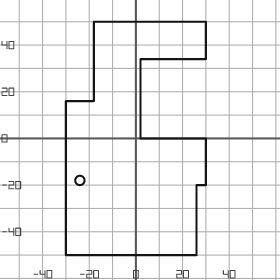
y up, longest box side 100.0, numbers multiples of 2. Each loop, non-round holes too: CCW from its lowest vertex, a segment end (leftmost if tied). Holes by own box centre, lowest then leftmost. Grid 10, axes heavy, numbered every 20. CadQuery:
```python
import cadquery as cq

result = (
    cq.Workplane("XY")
    .moveTo(-30.0, -50.0)
    .lineTo(26.0, -50.0)
    .lineTo(26.0, -20.0)
    .lineTo(30.0, -20.0)
    .lineTo(30.0, 0.0)
    .lineTo(2.0, 0.0)
    .lineTo(2.0, 34.0)
    .lineTo(30.0, 34.0)
    .lineTo(30.0, 50.0)
    .lineTo(-18.0, 50.0)
    .lineTo(-18.0, 16.0)
    .lineTo(-30.0, 16.0)
    .close()
    .moveTo(-24.0, -18.0)
    .circle(2.0)
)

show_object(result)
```